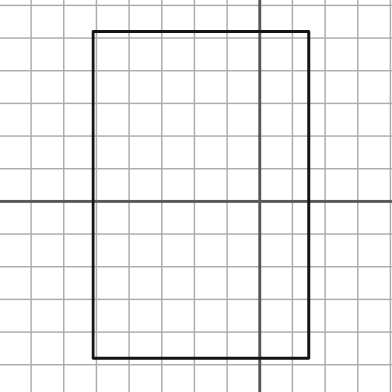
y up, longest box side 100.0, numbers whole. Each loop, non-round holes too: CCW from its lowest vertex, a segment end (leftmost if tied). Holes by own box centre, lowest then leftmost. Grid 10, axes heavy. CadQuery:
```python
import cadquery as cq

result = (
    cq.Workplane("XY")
    .moveTo(-51.0, -48.0)
    .lineTo(15.0, -48.0)
    .lineTo(15.0, 52.0)
    .lineTo(-51.0, 52.0)
    .close()
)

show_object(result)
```